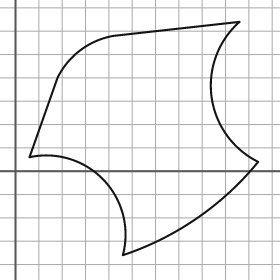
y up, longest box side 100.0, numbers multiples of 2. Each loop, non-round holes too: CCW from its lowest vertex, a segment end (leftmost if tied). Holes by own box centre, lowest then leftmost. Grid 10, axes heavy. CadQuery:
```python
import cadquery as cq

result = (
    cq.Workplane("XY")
    .moveTo(46.0, -36.0)
    .threePointArc((78.0, -20.0), (104.0, 4.0))
    .threePointArc((84.0, 32.0), (96.0, 64.0))
    .lineTo(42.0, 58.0)
    .threePointArc((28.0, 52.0), (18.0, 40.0))
    .lineTo(6.0, 6.0)
    .threePointArc((38.0, -4.0), (46.0, -36.0))
    .close()
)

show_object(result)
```